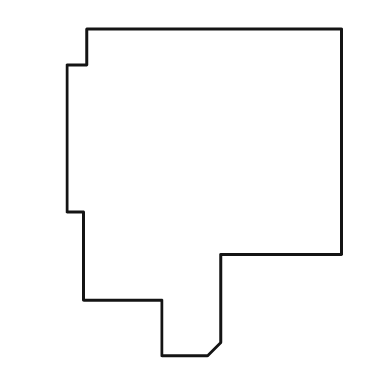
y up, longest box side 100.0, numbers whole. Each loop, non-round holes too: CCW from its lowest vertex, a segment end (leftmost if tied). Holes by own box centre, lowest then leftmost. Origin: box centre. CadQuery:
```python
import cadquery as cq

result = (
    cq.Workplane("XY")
    .moveTo(-13.0, -50.0)
    .lineTo(1.0, -50.0)
    .lineTo(5.0, -46.0)
    .lineTo(5.0, -19.0)
    .lineTo(42.0, -19.0)
    .lineTo(42.0, 50.0)
    .lineTo(-36.0, 50.0)
    .lineTo(-36.0, 39.0)
    .lineTo(-42.0, 39.0)
    .lineTo(-42.0, -6.0)
    .lineTo(-37.0, -6.0)
    .lineTo(-37.0, -33.0)
    .lineTo(-13.0, -33.0)
    .close()
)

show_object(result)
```